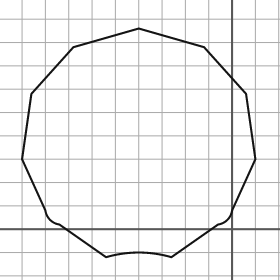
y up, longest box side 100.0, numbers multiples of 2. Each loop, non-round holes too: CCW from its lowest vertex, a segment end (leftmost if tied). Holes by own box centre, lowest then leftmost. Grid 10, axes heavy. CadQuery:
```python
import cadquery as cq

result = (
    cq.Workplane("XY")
    .moveTo(-54.0, -12.0)
    .threePointArc((-40.0, -10.0), (-26.0, -12.0))
    .lineTo(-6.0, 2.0)
    .threePointArc((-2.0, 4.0), (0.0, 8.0))
    .lineTo(10.0, 30.0)
    .lineTo(6.0, 58.0)
    .lineTo(-12.0, 78.0)
    .lineTo(-40.0, 86.0)
    .lineTo(-68.0, 78.0)
    .lineTo(-86.0, 58.0)
    .lineTo(-90.0, 30.0)
    .lineTo(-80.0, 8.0)
    .threePointArc((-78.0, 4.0), (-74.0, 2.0))
    .close()
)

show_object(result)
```